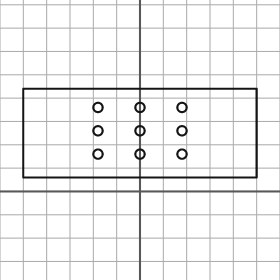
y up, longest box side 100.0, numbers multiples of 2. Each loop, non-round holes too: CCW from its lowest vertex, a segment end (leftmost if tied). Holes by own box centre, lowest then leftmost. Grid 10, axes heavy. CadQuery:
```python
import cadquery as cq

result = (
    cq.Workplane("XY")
    .moveTo(-50.0, 6.0)
    .lineTo(50.0, 6.0)
    .lineTo(50.0, 44.0)
    .lineTo(-50.0, 44.0)
    .close()
    .moveTo(-18.0, 16.0)
    .circle(2.0)
    .moveTo(0.0, 16.0)
    .circle(2.0)
    .moveTo(18.0, 16.0)
    .circle(2.0)
    .moveTo(-18.0, 26.0)
    .circle(2.0)
    .moveTo(0.0, 26.0)
    .circle(2.0)
    .moveTo(18.0, 26.0)
    .circle(2.0)
    .moveTo(-18.0, 36.0)
    .circle(2.0)
    .moveTo(0.0, 36.0)
    .circle(2.0)
    .moveTo(18.0, 36.0)
    .circle(2.0)
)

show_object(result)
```